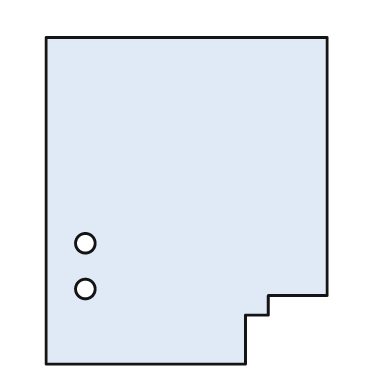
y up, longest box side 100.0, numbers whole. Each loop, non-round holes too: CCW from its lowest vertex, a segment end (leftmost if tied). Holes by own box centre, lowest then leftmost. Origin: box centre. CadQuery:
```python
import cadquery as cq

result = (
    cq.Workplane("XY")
    .moveTo(-43.0, -50.0)
    .lineTo(18.0, -50.0)
    .lineTo(18.0, -35.0)
    .lineTo(25.0, -35.0)
    .lineTo(25.0, -29.0)
    .lineTo(43.0, -29.0)
    .lineTo(43.0, 50.0)
    .lineTo(-43.0, 50.0)
    .close()
    .moveTo(-31.0, -27.0)
    .circle(3.0)
    .moveTo(-31.0, -13.0)
    .circle(3.0)
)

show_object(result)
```